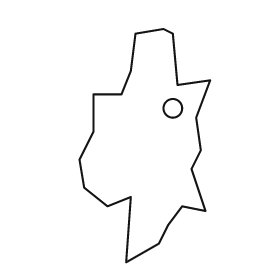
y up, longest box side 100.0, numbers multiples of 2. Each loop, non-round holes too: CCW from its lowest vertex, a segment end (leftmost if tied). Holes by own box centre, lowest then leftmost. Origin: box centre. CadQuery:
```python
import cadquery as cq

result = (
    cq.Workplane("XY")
    .moveTo(-8.0, -50.0)
    .lineTo(6.0, -42.0)
    .lineTo(10.0, -34.0)
    .lineTo(16.0, -26.0)
    .lineTo(26.0, -28.0)
    .lineTo(20.0, -10.0)
    .lineTo(24.0, -2.0)
    .lineTo(22.0, 12.0)
    .lineTo(28.0, 28.0)
    .lineTo(14.0, 26.0)
    .lineTo(12.0, 48.0)
    .lineTo(8.0, 50.0)
    .lineTo(-4.0, 48.0)
    .lineTo(-6.0, 32.0)
    .lineTo(-10.0, 22.0)
    .lineTo(-22.0, 22.0)
    .lineTo(-22.0, 6.0)
    .lineTo(-28.0, -6.0)
    .lineTo(-26.0, -18.0)
    .lineTo(-16.0, -26.0)
    .lineTo(-6.0, -22.0)
    .close()
    .moveTo(12.0, 16.0)
    .circle(4.0)
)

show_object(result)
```